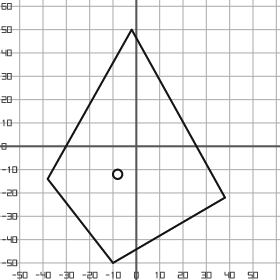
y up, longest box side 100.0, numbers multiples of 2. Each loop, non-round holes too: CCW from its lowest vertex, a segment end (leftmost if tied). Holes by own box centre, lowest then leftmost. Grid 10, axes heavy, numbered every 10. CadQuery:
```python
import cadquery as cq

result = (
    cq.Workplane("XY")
    .moveTo(-10.0, -50.0)
    .lineTo(38.0, -22.0)
    .lineTo(-2.0, 50.0)
    .lineTo(-38.0, -14.0)
    .close()
    .moveTo(-8.0, -12.0)
    .circle(2.0)
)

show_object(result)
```